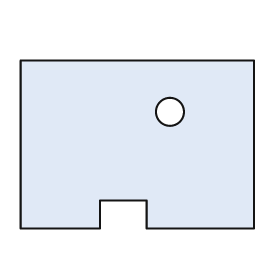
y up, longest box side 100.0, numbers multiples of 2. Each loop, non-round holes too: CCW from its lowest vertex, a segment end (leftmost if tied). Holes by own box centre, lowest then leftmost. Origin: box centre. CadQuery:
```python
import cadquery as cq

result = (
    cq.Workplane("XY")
    .moveTo(-50.0, -36.0)
    .lineTo(-16.0, -36.0)
    .lineTo(-16.0, -24.0)
    .lineTo(4.0, -24.0)
    .lineTo(4.0, -36.0)
    .lineTo(50.0, -36.0)
    .lineTo(50.0, 36.0)
    .lineTo(-50.0, 36.0)
    .close()
    .moveTo(14.0, 14.0)
    .circle(6.0)
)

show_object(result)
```